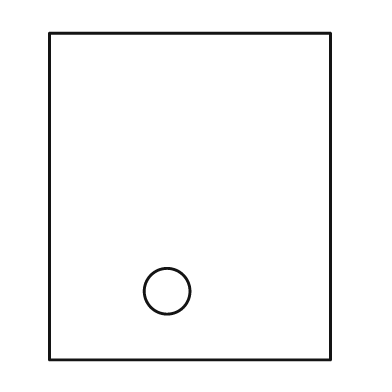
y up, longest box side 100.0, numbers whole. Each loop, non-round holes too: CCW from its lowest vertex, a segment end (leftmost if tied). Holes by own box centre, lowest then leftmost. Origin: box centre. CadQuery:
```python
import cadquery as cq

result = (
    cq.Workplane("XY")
    .moveTo(-43.0, -50.0)
    .lineTo(43.0, -50.0)
    .lineTo(43.0, 50.0)
    .lineTo(-43.0, 50.0)
    .close()
    .moveTo(-7.0, -29.0)
    .circle(7.0)
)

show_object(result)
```